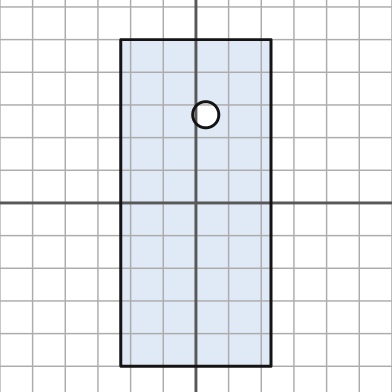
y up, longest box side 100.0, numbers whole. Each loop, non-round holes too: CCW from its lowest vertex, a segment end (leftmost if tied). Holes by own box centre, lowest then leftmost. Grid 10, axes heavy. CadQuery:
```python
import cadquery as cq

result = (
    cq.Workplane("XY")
    .moveTo(-23.0, -50.0)
    .lineTo(23.0, -50.0)
    .lineTo(23.0, 50.0)
    .lineTo(-23.0, 50.0)
    .close()
    .moveTo(3.0, 27.0)
    .circle(4.0)
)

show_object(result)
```